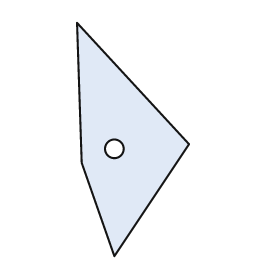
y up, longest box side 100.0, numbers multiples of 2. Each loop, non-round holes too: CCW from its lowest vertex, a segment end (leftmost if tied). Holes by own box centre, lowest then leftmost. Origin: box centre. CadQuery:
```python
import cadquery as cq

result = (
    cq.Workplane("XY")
    .moveTo(-8.0, -50.0)
    .lineTo(24.0, -2.0)
    .lineTo(-24.0, 50.0)
    .lineTo(-22.0, -10.0)
    .close()
    .moveTo(-8.0, -4.0)
    .circle(4.0)
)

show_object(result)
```